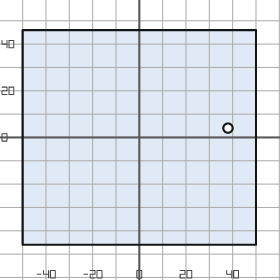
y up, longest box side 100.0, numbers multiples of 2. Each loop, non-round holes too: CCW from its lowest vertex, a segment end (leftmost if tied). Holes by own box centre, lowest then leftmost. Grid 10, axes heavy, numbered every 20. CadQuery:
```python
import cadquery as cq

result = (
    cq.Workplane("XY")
    .moveTo(-50.0, -46.0)
    .lineTo(50.0, -46.0)
    .lineTo(50.0, 46.0)
    .lineTo(-50.0, 46.0)
    .close()
    .moveTo(38.0, 4.0)
    .circle(2.0)
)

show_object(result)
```